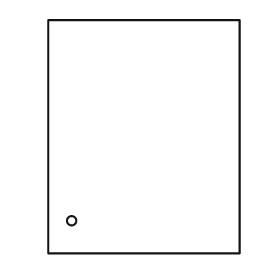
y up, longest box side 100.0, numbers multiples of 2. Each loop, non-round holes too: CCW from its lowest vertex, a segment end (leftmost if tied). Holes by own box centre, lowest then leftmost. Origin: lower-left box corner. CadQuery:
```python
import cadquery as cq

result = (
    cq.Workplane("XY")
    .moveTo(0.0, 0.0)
    .lineTo(82.0, 0.0)
    .lineTo(82.0, 100.0)
    .lineTo(0.0, 100.0)
    .close()
    .moveTo(10.0, 14.0)
    .circle(2.0)
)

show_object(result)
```